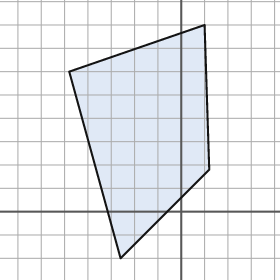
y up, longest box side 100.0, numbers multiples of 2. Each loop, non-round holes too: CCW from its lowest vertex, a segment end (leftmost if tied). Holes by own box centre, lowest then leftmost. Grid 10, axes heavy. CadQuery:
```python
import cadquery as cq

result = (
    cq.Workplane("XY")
    .moveTo(-26.0, -20.0)
    .lineTo(12.0, 18.0)
    .lineTo(10.0, 80.0)
    .lineTo(-48.0, 60.0)
    .close()
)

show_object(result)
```